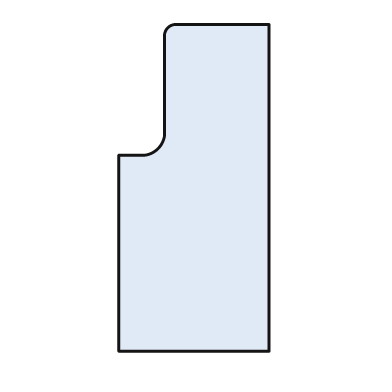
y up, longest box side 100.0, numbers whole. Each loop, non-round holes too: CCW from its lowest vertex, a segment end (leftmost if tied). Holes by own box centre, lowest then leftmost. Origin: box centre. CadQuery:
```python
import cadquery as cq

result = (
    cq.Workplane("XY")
    .moveTo(-23.0, -50.0)
    .lineTo(23.0, -50.0)
    .lineTo(23.0, 50.0)
    .lineTo(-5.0, 50.0)
    .threePointArc((-8.0, 49.0), (-9.0, 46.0))
    .lineTo(-9.0, 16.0)
    .threePointArc((-11.0, 12.0), (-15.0, 10.0))
    .lineTo(-23.0, 10.0)
    .close()
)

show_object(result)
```